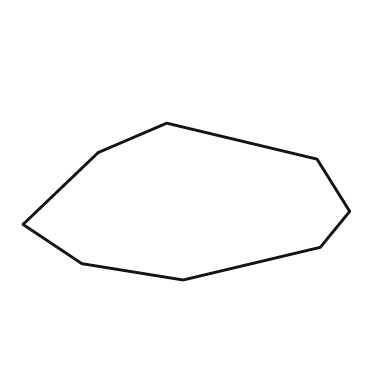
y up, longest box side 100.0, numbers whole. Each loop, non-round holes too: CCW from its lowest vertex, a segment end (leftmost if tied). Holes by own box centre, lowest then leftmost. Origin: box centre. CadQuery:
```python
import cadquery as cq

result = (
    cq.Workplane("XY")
    .moveTo(-1.0, -24.0)
    .lineTo(41.0, -14.0)
    .lineTo(50.0, -3.0)
    .lineTo(40.0, 13.0)
    .lineTo(-6.0, 24.0)
    .lineTo(-27.0, 15.0)
    .lineTo(-50.0, -7.0)
    .lineTo(-32.0, -19.0)
    .close()
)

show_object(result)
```